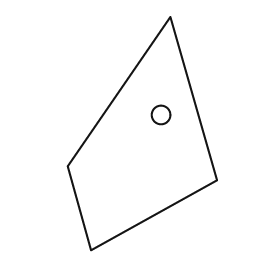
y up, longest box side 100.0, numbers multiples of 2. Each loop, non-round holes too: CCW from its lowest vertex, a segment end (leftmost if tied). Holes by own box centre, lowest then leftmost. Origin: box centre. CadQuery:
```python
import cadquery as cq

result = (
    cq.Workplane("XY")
    .moveTo(-22.0, -50.0)
    .lineTo(32.0, -20.0)
    .lineTo(12.0, 50.0)
    .lineTo(-32.0, -14.0)
    .close()
    .moveTo(8.0, 8.0)
    .circle(4.0)
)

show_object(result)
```